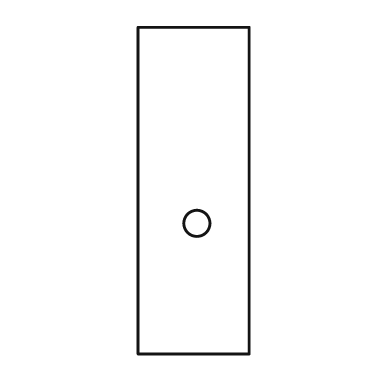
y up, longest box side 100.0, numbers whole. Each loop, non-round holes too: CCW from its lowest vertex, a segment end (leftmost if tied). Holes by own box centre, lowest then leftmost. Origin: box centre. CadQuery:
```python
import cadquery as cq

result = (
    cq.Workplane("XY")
    .moveTo(-17.0, -50.0)
    .lineTo(17.0, -50.0)
    .lineTo(17.0, 50.0)
    .lineTo(-17.0, 50.0)
    .close()
    .moveTo(1.0, -10.0)
    .circle(4.0)
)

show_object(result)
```